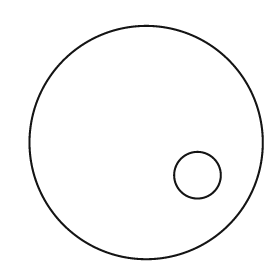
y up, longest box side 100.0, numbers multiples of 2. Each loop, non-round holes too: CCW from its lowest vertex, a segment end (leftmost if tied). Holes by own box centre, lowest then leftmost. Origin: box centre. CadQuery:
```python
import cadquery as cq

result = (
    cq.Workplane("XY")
    .moveTo(0.0, 0.0)
    .circle(50.0)
    .moveTo(22.0, -14.0)
    .circle(10.0)
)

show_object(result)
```